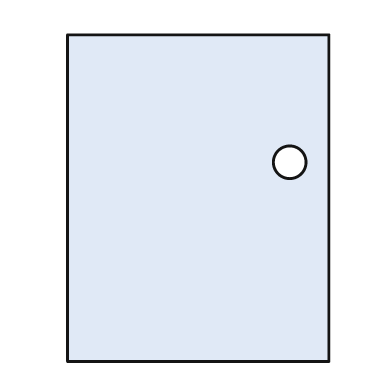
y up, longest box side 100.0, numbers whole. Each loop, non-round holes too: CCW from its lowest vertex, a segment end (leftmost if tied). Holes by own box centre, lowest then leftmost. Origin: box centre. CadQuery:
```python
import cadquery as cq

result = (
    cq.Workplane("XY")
    .moveTo(-40.0, -50.0)
    .lineTo(40.0, -50.0)
    .lineTo(40.0, 50.0)
    .lineTo(-40.0, 50.0)
    .close()
    .moveTo(28.0, 11.0)
    .circle(5.0)
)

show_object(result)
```